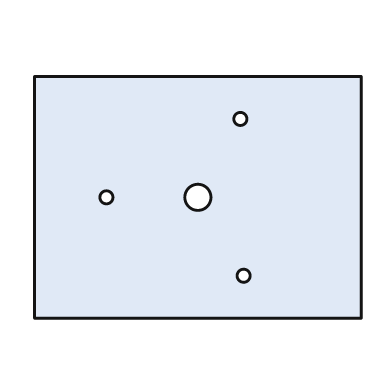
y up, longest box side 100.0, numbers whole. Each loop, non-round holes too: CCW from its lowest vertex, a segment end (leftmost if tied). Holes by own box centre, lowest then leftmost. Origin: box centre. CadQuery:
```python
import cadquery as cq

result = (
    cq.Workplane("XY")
    .moveTo(-50.0, -37.0)
    .lineTo(50.0, -37.0)
    .lineTo(50.0, 37.0)
    .lineTo(-50.0, 37.0)
    .close()
    .moveTo(14.0, -24.0)
    .circle(2.0)
    .moveTo(-28.0, 0.0)
    .circle(2.0)
    .moveTo(0.0, 0.0)
    .circle(4.0)
    .moveTo(13.0, 24.0)
    .circle(2.0)
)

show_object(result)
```